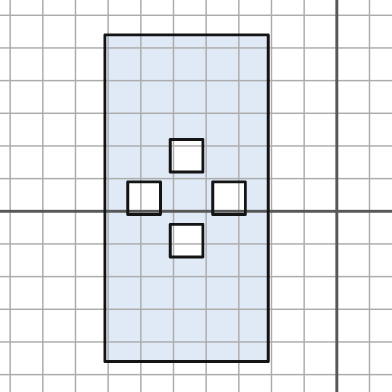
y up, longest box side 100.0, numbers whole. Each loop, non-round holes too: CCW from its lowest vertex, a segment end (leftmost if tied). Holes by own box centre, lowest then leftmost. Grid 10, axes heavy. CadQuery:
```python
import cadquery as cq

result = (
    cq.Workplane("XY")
    .moveTo(-71.0, -46.0)
    .lineTo(-21.0, -46.0)
    .lineTo(-21.0, 54.0)
    .lineTo(-71.0, 54.0)
    .close()
    .moveTo(-51.0, -14.0)
    .lineTo(-41.0, -14.0)
    .lineTo(-41.0, -4.0)
    .lineTo(-51.0, -4.0)
    .close()
    .moveTo(-64.0, -1.0)
    .lineTo(-54.0, -1.0)
    .lineTo(-54.0, 9.0)
    .lineTo(-64.0, 9.0)
    .close()
    .moveTo(-38.0, -1.0)
    .lineTo(-28.0, -1.0)
    .lineTo(-28.0, 9.0)
    .lineTo(-38.0, 9.0)
    .close()
    .moveTo(-51.0, 12.0)
    .lineTo(-41.0, 12.0)
    .lineTo(-41.0, 22.0)
    .lineTo(-51.0, 22.0)
    .close()
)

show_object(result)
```